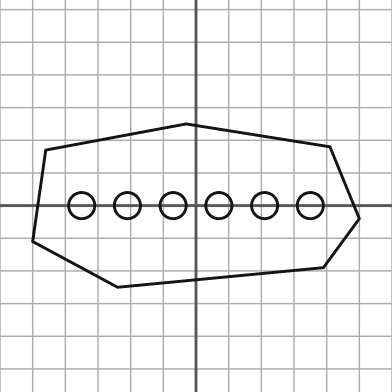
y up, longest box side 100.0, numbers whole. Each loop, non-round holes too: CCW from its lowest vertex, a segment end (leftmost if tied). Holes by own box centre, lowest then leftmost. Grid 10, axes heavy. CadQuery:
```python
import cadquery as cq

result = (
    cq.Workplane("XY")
    .moveTo(-24.0, -25.0)
    .lineTo(39.0, -19.0)
    .lineTo(50.0, -4.0)
    .lineTo(41.0, 18.0)
    .lineTo(-3.0, 25.0)
    .lineTo(-46.0, 17.0)
    .lineTo(-50.0, -11.0)
    .close()
    .moveTo(-35.0, 0.0)
    .circle(4.0)
    .moveTo(-21.0, 0.0)
    .circle(4.0)
    .moveTo(-7.0, 0.0)
    .circle(4.0)
    .moveTo(7.0, 0.0)
    .circle(4.0)
    .moveTo(21.0, 0.0)
    .circle(4.0)
    .moveTo(35.0, 0.0)
    .circle(4.0)
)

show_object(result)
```